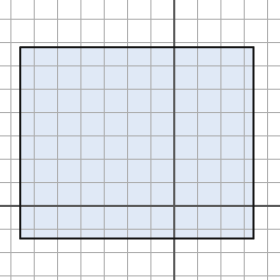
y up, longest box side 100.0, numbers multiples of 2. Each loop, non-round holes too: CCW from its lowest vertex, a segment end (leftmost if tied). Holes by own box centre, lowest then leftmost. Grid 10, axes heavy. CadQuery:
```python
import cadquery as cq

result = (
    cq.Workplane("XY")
    .moveTo(-66.0, -14.0)
    .lineTo(34.0, -14.0)
    .lineTo(34.0, 68.0)
    .lineTo(-66.0, 68.0)
    .close()
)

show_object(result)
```